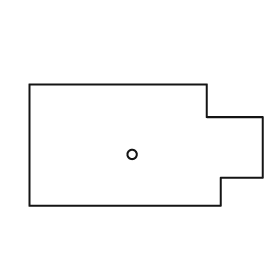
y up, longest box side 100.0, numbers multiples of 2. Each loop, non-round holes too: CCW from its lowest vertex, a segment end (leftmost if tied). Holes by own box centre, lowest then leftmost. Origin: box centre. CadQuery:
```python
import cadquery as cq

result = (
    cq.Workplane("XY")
    .moveTo(-50.0, -26.0)
    .lineTo(32.0, -26.0)
    .lineTo(32.0, -14.0)
    .lineTo(50.0, -14.0)
    .lineTo(50.0, 12.0)
    .lineTo(26.0, 12.0)
    .lineTo(26.0, 26.0)
    .lineTo(-50.0, 26.0)
    .close()
    .moveTo(-6.0, -4.0)
    .circle(2.0)
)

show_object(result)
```